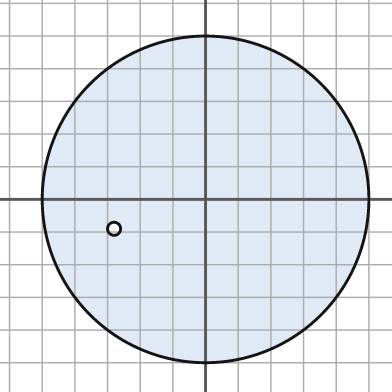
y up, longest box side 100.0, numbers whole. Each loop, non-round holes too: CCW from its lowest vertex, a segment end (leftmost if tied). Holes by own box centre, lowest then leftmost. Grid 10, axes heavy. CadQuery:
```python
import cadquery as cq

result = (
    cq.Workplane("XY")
    .moveTo(0.0, 0.0)
    .circle(50.0)
    .moveTo(-28.0, -9.0)
    .circle(2.0)
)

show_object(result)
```